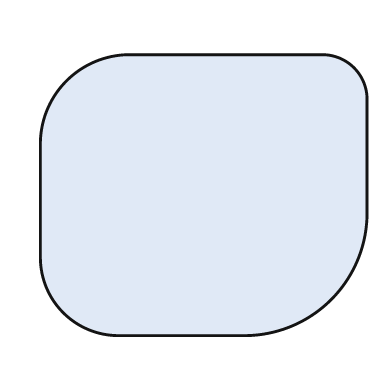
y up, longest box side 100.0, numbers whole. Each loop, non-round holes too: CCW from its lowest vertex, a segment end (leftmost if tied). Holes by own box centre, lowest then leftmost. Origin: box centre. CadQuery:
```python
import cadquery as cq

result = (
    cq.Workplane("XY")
    .moveTo(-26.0, -43.0)
    .lineTo(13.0, -43.0)
    .threePointArc((39.0, -32.0), (50.0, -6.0))
    .lineTo(50.0, 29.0)
    .threePointArc((46.0, 39.0), (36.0, 43.0))
    .lineTo(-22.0, 43.0)
    .threePointArc((-42.0, 35.0), (-50.0, 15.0))
    .lineTo(-50.0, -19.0)
    .threePointArc((-43.0, -36.0), (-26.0, -43.0))
    .close()
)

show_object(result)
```